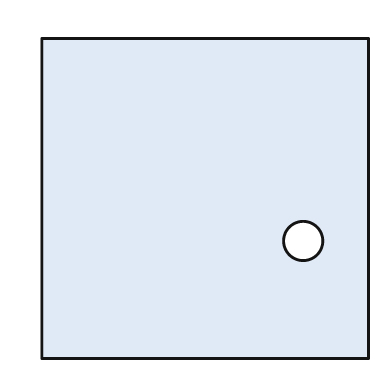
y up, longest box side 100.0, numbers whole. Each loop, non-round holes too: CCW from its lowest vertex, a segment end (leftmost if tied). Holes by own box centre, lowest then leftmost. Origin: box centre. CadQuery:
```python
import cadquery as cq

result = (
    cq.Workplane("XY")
    .moveTo(-50.0, -49.0)
    .lineTo(50.0, -49.0)
    .lineTo(50.0, 49.0)
    .lineTo(-50.0, 49.0)
    .close()
    .moveTo(30.0, -13.0)
    .circle(6.0)
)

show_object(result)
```